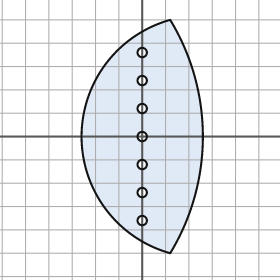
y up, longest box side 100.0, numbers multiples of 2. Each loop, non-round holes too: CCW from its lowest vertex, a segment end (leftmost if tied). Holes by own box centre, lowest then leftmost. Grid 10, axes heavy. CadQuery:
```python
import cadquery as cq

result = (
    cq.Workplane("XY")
    .moveTo(12.0, -50.0)
    .threePointArc((26.0, 0.0), (12.0, 50.0))
    .threePointArc((-26.0, 0.0), (12.0, -50.0))
    .close()
    .moveTo(0.0, -36.0)
    .circle(2.0)
    .moveTo(0.0, -24.0)
    .circle(2.0)
    .moveTo(0.0, -12.0)
    .circle(2.0)
    .moveTo(0.0, 0.0)
    .circle(2.0)
    .moveTo(0.0, 12.0)
    .circle(2.0)
    .moveTo(0.0, 24.0)
    .circle(2.0)
    .moveTo(0.0, 36.0)
    .circle(2.0)
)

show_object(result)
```